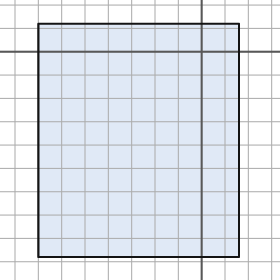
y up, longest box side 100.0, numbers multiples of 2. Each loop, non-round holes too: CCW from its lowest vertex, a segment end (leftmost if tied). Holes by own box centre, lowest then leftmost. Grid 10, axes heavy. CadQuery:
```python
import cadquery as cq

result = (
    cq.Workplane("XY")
    .moveTo(-70.0, -88.0)
    .lineTo(16.0, -88.0)
    .lineTo(16.0, 12.0)
    .lineTo(-70.0, 12.0)
    .close()
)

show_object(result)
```